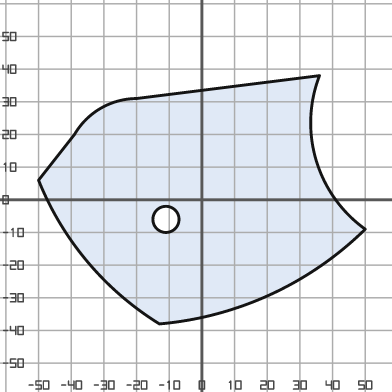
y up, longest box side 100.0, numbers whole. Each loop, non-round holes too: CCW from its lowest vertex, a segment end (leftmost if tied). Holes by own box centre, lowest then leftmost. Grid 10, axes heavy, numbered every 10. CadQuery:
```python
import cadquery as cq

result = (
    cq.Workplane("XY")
    .moveTo(-13.0, -38.0)
    .threePointArc((21.0, -29.0), (50.0, -9.0))
    .threePointArc((35.0, 12.0), (36.0, 38.0))
    .lineTo(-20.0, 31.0)
    .threePointArc((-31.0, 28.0), (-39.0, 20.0))
    .lineTo(-50.0, 6.0)
    .threePointArc((-35.0, -19.0), (-13.0, -38.0))
    .close()
    .moveTo(-11.0, -6.0)
    .circle(4.0)
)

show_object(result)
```